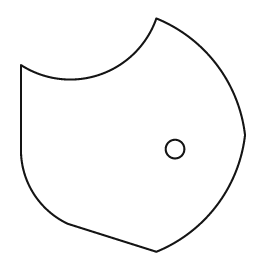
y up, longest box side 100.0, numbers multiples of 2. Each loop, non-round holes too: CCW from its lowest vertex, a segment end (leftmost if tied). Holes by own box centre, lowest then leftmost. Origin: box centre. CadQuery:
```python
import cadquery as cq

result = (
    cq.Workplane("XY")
    .moveTo(10.0, -50.0)
    .threePointArc((36.0, -30.0), (48.0, 0.0))
    .threePointArc((36.0, 30.0), (10.0, 50.0))
    .threePointArc((-14.0, 26.0), (-48.0, 30.0))
    .lineTo(-48.0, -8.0)
    .threePointArc((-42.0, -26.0), (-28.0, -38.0))
    .close()
    .moveTo(18.0, -6.0)
    .circle(4.0)
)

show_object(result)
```